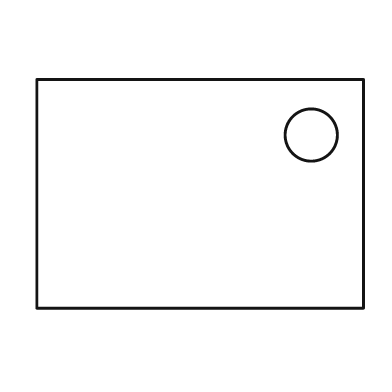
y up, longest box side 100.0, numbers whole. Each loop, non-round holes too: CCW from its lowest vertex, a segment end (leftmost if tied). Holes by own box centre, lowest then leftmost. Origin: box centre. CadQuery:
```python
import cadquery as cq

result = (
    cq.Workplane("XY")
    .moveTo(-50.0, -35.0)
    .lineTo(50.0, -35.0)
    .lineTo(50.0, 35.0)
    .lineTo(-50.0, 35.0)
    .close()
    .moveTo(34.0, 18.0)
    .circle(8.0)
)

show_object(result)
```